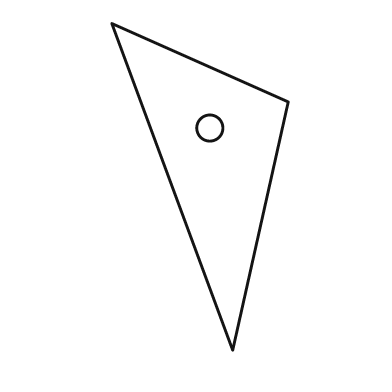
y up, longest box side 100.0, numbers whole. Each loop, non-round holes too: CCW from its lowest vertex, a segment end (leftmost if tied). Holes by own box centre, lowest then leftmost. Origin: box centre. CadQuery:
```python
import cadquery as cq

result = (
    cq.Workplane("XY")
    .moveTo(10.0, -50.0)
    .lineTo(27.0, 26.0)
    .lineTo(-27.0, 50.0)
    .close()
    .moveTo(3.0, 18.0)
    .circle(4.0)
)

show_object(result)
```